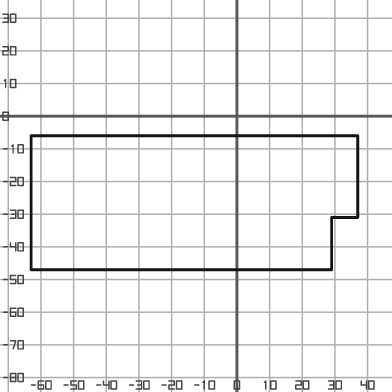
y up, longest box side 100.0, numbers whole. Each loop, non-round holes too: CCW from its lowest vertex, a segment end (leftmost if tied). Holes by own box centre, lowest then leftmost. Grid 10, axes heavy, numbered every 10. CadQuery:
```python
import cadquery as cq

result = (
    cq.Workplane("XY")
    .moveTo(-63.0, -47.0)
    .lineTo(29.0, -47.0)
    .lineTo(29.0, -31.0)
    .lineTo(37.0, -31.0)
    .lineTo(37.0, -6.0)
    .lineTo(-63.0, -6.0)
    .close()
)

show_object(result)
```